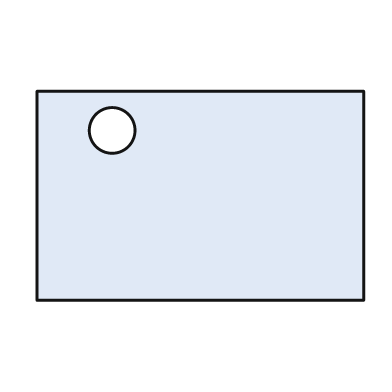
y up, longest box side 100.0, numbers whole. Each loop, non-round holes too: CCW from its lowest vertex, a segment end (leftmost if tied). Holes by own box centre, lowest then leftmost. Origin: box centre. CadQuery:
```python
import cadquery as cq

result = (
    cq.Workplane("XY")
    .moveTo(-50.0, -32.0)
    .lineTo(50.0, -32.0)
    .lineTo(50.0, 32.0)
    .lineTo(-50.0, 32.0)
    .close()
    .moveTo(-27.0, 20.0)
    .circle(7.0)
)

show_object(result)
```